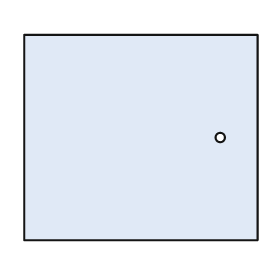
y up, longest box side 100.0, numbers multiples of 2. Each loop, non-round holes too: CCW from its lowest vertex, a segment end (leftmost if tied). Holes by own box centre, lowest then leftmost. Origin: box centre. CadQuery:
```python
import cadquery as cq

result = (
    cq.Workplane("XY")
    .moveTo(-50.0, -44.0)
    .lineTo(50.0, -44.0)
    .lineTo(50.0, 44.0)
    .lineTo(-50.0, 44.0)
    .close()
    .moveTo(34.0, 0.0)
    .circle(2.0)
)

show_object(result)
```